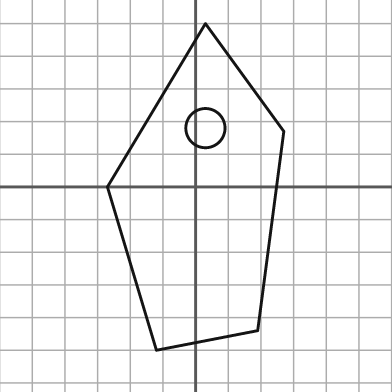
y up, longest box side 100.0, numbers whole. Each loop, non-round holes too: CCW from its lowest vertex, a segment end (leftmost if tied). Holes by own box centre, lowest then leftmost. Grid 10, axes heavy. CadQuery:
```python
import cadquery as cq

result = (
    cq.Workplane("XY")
    .moveTo(-12.0, -50.0)
    .lineTo(19.0, -44.0)
    .lineTo(27.0, 17.0)
    .lineTo(3.0, 50.0)
    .lineTo(-27.0, 0.0)
    .close()
    .moveTo(3.0, 18.0)
    .circle(6.0)
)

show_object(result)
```